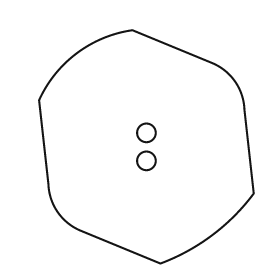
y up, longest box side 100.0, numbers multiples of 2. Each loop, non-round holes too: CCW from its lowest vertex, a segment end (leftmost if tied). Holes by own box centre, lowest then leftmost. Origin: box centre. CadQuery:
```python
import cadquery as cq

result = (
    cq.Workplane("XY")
    .moveTo(6.0, -50.0)
    .threePointArc((28.0, -38.0), (46.0, -20.0))
    .lineTo(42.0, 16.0)
    .threePointArc((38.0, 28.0), (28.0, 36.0))
    .lineTo(-6.0, 50.0)
    .threePointArc((-30.0, 40.0), (-46.0, 20.0))
    .lineTo(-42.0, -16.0)
    .threePointArc((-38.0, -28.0), (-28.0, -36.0))
    .close()
    .moveTo(0.0, -6.0)
    .circle(4.0)
    .moveTo(0.0, 6.0)
    .circle(4.0)
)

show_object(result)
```